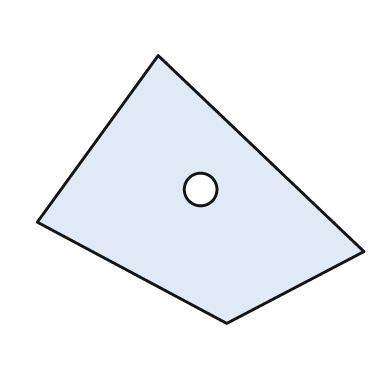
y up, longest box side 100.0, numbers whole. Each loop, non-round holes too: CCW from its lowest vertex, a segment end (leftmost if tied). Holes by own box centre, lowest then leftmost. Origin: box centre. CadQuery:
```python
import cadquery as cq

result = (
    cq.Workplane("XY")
    .moveTo(8.0, -41.0)
    .lineTo(50.0, -19.0)
    .lineTo(-13.0, 41.0)
    .lineTo(-50.0, -10.0)
    .close()
    .moveTo(0.0, 0.0)
    .circle(5.0)
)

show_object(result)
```